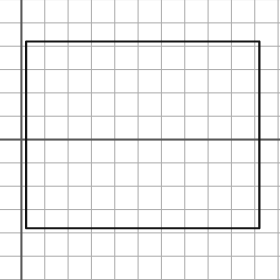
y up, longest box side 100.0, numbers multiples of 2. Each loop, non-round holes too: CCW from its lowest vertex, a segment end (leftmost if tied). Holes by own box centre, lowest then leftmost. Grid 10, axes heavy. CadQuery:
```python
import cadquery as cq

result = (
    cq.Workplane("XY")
    .moveTo(2.0, -38.0)
    .lineTo(102.0, -38.0)
    .lineTo(102.0, 42.0)
    .lineTo(2.0, 42.0)
    .close()
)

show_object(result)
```